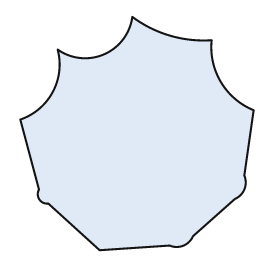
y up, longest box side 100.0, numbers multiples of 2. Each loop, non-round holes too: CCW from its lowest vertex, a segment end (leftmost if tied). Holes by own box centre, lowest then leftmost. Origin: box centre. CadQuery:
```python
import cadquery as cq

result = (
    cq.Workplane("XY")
    .moveTo(-16.0, -50.0)
    .lineTo(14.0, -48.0)
    .threePointArc((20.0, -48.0), (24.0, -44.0))
    .lineTo(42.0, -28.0)
    .threePointArc((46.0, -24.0), (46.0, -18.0))
    .lineTo(50.0, 10.0)
    .threePointArc((36.0, 22.0), (32.0, 40.0))
    .threePointArc((14.0, 42.0), (-2.0, 50.0))
    .threePointArc((-14.0, 34.0), (-34.0, 36.0))
    .threePointArc((-36.0, 18.0), (-50.0, 6.0))
    .lineTo(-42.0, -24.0)
    .threePointArc((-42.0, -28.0), (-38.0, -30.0))
    .close()
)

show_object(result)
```